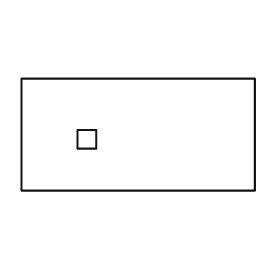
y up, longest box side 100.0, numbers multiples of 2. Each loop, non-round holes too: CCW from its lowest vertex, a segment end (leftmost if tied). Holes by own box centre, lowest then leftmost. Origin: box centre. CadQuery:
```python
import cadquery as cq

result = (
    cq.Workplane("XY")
    .moveTo(-50.0, -24.0)
    .lineTo(50.0, -24.0)
    .lineTo(50.0, 24.0)
    .lineTo(-50.0, 24.0)
    .close()
    .moveTo(-26.0, -6.0)
    .lineTo(-18.0, -6.0)
    .lineTo(-18.0, 2.0)
    .lineTo(-26.0, 2.0)
    .close()
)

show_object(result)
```